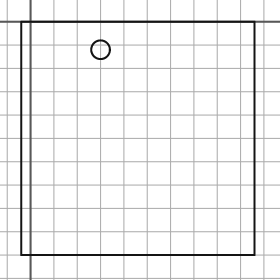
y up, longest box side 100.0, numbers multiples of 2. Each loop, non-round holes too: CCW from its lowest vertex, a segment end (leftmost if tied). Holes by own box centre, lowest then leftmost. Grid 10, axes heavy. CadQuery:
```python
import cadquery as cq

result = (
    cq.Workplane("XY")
    .moveTo(-4.0, -100.0)
    .lineTo(96.0, -100.0)
    .lineTo(96.0, 0.0)
    .lineTo(-4.0, 0.0)
    .close()
    .moveTo(30.0, -12.0)
    .circle(4.0)
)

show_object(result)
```